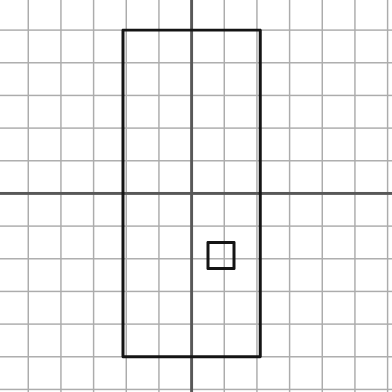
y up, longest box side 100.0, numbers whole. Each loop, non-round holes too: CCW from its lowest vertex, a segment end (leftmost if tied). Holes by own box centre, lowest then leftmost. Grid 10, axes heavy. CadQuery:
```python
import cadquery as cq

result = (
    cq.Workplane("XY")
    .moveTo(-21.0, -50.0)
    .lineTo(21.0, -50.0)
    .lineTo(21.0, 50.0)
    .lineTo(-21.0, 50.0)
    .close()
    .moveTo(5.0, -23.0)
    .lineTo(13.0, -23.0)
    .lineTo(13.0, -15.0)
    .lineTo(5.0, -15.0)
    .close()
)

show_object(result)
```